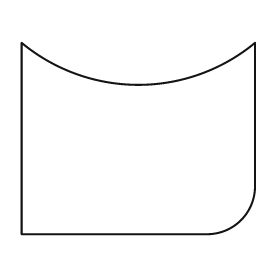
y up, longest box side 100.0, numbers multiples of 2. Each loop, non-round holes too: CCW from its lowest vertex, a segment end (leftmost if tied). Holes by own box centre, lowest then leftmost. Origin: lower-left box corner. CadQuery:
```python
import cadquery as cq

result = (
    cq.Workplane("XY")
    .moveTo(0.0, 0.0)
    .lineTo(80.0, 0.0)
    .threePointArc((94.0, 6.0), (100.0, 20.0))
    .lineTo(100.0, 82.0)
    .threePointArc((50.0, 64.0), (0.0, 82.0))
    .close()
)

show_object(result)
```